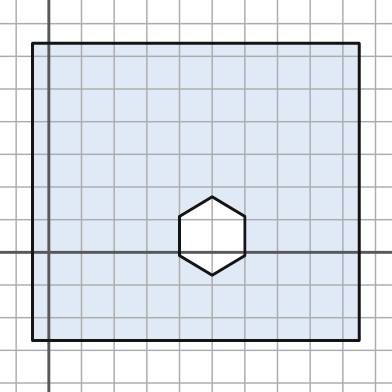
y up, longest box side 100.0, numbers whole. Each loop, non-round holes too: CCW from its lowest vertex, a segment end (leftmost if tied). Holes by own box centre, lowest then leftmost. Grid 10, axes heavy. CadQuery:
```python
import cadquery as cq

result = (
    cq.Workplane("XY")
    .moveTo(-5.0, -27.0)
    .lineTo(95.0, -27.0)
    .lineTo(95.0, 64.0)
    .lineTo(-5.0, 64.0)
    .close()
    .moveTo(50.0, -7.0)
    .lineTo(60.0, -1.0)
    .lineTo(60.0, 11.0)
    .lineTo(50.0, 17.0)
    .lineTo(40.0, 11.0)
    .lineTo(40.0, -1.0)
    .close()
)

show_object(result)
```